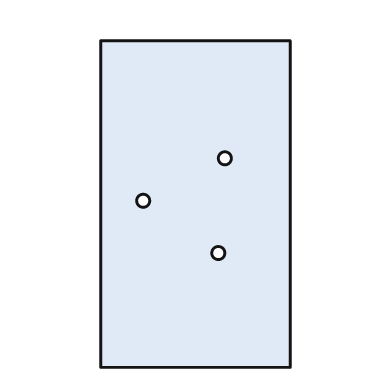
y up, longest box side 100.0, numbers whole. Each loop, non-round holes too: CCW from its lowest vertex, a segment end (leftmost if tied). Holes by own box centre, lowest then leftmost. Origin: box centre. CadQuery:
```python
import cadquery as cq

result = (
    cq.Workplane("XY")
    .moveTo(-29.0, -50.0)
    .lineTo(29.0, -50.0)
    .lineTo(29.0, 50.0)
    .lineTo(-29.0, 50.0)
    .close()
    .moveTo(7.0, -15.0)
    .circle(2.0)
    .moveTo(-16.0, 1.0)
    .circle(2.0)
    .moveTo(9.0, 14.0)
    .circle(2.0)
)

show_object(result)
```